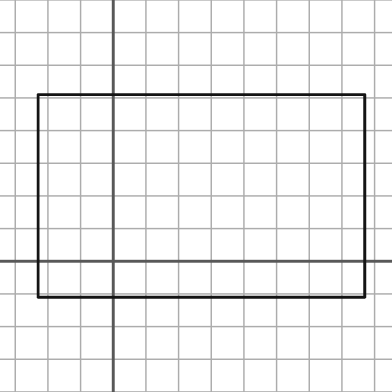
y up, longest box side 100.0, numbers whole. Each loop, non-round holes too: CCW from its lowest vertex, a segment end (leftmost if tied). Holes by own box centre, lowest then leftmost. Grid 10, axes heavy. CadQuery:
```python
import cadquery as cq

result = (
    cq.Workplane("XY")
    .moveTo(-23.0, -11.0)
    .lineTo(77.0, -11.0)
    .lineTo(77.0, 51.0)
    .lineTo(-23.0, 51.0)
    .close()
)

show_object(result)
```